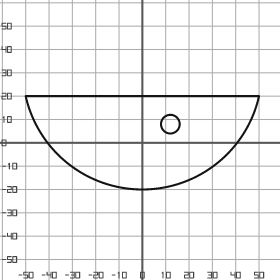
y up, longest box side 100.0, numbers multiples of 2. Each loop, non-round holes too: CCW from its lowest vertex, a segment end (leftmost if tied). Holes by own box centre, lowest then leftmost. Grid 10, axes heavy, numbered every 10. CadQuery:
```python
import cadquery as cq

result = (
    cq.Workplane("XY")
    .moveTo(-50.0, 20.0)
    .threePointArc((0.0, -20.0), (50.0, 20.0))
    .close()
    .moveTo(12.0, 8.0)
    .circle(4.0)
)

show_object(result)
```